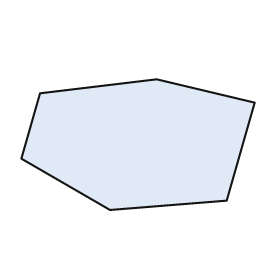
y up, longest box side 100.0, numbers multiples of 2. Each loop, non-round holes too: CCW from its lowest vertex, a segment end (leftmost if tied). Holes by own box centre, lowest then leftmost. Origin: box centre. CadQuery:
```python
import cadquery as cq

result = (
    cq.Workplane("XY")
    .moveTo(-12.0, -28.0)
    .lineTo(38.0, -24.0)
    .lineTo(50.0, 18.0)
    .lineTo(8.0, 28.0)
    .lineTo(-42.0, 22.0)
    .lineTo(-50.0, -6.0)
    .close()
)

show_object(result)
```